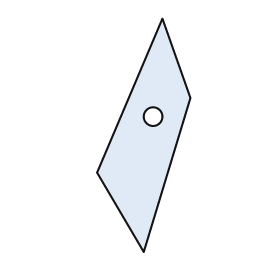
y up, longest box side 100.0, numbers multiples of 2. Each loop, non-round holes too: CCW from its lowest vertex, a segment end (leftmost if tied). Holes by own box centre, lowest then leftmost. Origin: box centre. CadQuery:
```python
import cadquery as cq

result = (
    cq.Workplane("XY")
    .moveTo(0.0, -50.0)
    .lineTo(20.0, 16.0)
    .lineTo(8.0, 50.0)
    .lineTo(-20.0, -16.0)
    .close()
    .moveTo(4.0, 8.0)
    .circle(4.0)
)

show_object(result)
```